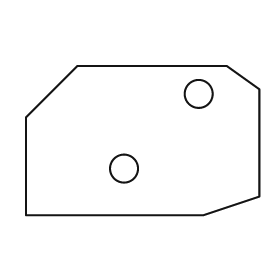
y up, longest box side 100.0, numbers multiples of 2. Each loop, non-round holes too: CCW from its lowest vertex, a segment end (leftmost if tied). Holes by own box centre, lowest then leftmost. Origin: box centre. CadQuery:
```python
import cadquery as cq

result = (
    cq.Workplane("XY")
    .moveTo(-50.0, -32.0)
    .lineTo(26.0, -32.0)
    .lineTo(50.0, -24.0)
    .lineTo(50.0, 22.0)
    .lineTo(36.0, 32.0)
    .lineTo(-28.0, 32.0)
    .lineTo(-50.0, 10.0)
    .close()
    .moveTo(-8.0, -12.0)
    .circle(6.0)
    .moveTo(24.0, 20.0)
    .circle(6.0)
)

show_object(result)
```